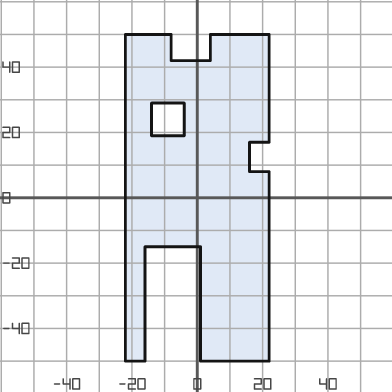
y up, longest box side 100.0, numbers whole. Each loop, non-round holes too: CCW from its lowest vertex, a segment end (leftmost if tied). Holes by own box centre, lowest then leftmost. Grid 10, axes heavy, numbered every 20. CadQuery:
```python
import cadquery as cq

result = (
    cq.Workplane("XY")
    .moveTo(-22.0, -50.0)
    .lineTo(-16.0, -50.0)
    .lineTo(-16.0, -15.0)
    .lineTo(1.0, -15.0)
    .lineTo(1.0, -50.0)
    .lineTo(22.0, -50.0)
    .lineTo(22.0, 8.0)
    .lineTo(16.0, 8.0)
    .lineTo(16.0, 17.0)
    .lineTo(22.0, 17.0)
    .lineTo(22.0, 50.0)
    .lineTo(4.0, 50.0)
    .lineTo(4.0, 42.0)
    .lineTo(-8.0, 42.0)
    .lineTo(-8.0, 50.0)
    .lineTo(-22.0, 50.0)
    .close()
    .moveTo(-14.0, 19.0)
    .lineTo(-4.0, 19.0)
    .lineTo(-4.0, 29.0)
    .lineTo(-14.0, 29.0)
    .close()
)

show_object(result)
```